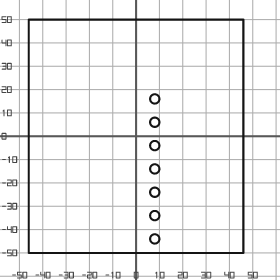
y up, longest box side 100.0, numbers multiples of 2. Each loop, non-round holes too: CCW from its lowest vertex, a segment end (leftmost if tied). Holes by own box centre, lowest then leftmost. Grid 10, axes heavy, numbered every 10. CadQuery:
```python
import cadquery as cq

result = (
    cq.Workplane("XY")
    .moveTo(-46.0, -50.0)
    .lineTo(46.0, -50.0)
    .lineTo(46.0, 50.0)
    .lineTo(-46.0, 50.0)
    .close()
    .moveTo(8.0, -44.0)
    .circle(2.0)
    .moveTo(8.0, -34.0)
    .circle(2.0)
    .moveTo(8.0, -24.0)
    .circle(2.0)
    .moveTo(8.0, -14.0)
    .circle(2.0)
    .moveTo(8.0, -4.0)
    .circle(2.0)
    .moveTo(8.0, 6.0)
    .circle(2.0)
    .moveTo(8.0, 16.0)
    .circle(2.0)
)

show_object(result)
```